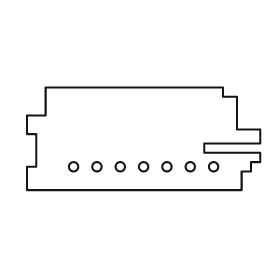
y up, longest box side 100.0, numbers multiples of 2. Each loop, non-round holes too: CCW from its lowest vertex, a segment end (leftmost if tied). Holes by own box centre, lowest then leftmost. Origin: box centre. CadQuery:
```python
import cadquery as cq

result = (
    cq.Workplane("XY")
    .moveTo(-50.0, -22.0)
    .lineTo(42.0, -22.0)
    .lineTo(42.0, -14.0)
    .lineTo(46.0, -14.0)
    .lineTo(46.0, -10.0)
    .lineTo(50.0, -10.0)
    .lineTo(50.0, -6.0)
    .lineTo(26.0, -6.0)
    .lineTo(26.0, -2.0)
    .lineTo(50.0, -2.0)
    .lineTo(50.0, 4.0)
    .lineTo(40.0, 4.0)
    .lineTo(40.0, 18.0)
    .lineTo(34.0, 18.0)
    .lineTo(34.0, 22.0)
    .lineTo(-42.0, 22.0)
    .lineTo(-42.0, 10.0)
    .lineTo(-50.0, 10.0)
    .lineTo(-50.0, 2.0)
    .lineTo(-46.0, 2.0)
    .lineTo(-46.0, -12.0)
    .lineTo(-50.0, -12.0)
    .close()
    .moveTo(-30.0, -12.0)
    .circle(2.0)
    .moveTo(-20.0, -12.0)
    .circle(2.0)
    .moveTo(-10.0, -12.0)
    .circle(2.0)
    .moveTo(0.0, -12.0)
    .circle(2.0)
    .moveTo(10.0, -12.0)
    .circle(2.0)
    .moveTo(20.0, -12.0)
    .circle(2.0)
    .moveTo(30.0, -12.0)
    .circle(2.0)
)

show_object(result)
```